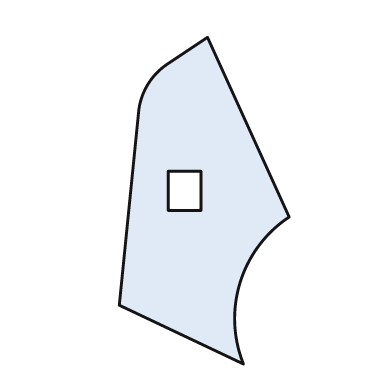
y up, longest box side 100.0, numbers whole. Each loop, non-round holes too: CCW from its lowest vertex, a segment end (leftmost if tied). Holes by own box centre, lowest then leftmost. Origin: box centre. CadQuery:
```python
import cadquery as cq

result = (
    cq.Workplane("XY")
    .moveTo(12.0, -50.0)
    .threePointArc((11.0, -25.0), (26.0, -5.0))
    .lineTo(1.0, 50.0)
    .lineTo(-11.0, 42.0)
    .threePointArc((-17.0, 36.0), (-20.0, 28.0))
    .lineTo(-26.0, -32.0)
    .close()
    .moveTo(-11.0, -3.0)
    .lineTo(-1.0, -3.0)
    .lineTo(-1.0, 9.0)
    .lineTo(-11.0, 9.0)
    .close()
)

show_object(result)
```